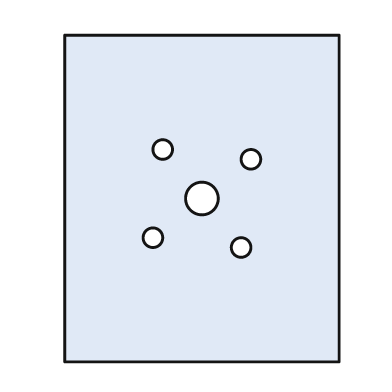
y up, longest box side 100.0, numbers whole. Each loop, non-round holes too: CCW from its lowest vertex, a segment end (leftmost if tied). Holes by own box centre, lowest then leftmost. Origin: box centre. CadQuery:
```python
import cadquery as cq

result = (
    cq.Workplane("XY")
    .moveTo(-42.0, -50.0)
    .lineTo(42.0, -50.0)
    .lineTo(42.0, 50.0)
    .lineTo(-42.0, 50.0)
    .close()
    .moveTo(12.0, -15.0)
    .circle(3.0)
    .moveTo(-15.0, -12.0)
    .circle(3.0)
    .moveTo(0.0, 0.0)
    .circle(5.0)
    .moveTo(15.0, 12.0)
    .circle(3.0)
    .moveTo(-12.0, 15.0)
    .circle(3.0)
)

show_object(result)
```